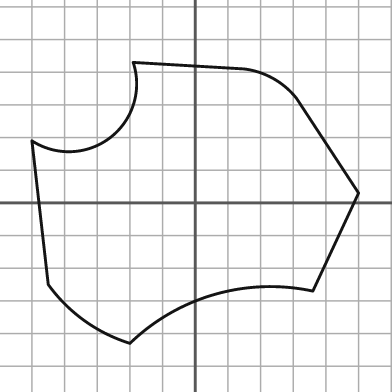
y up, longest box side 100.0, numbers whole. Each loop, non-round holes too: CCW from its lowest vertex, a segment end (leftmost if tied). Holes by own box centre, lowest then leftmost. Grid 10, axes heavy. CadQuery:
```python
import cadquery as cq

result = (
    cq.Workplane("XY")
    .moveTo(-20.0, -43.0)
    .threePointArc((6.0, -28.0), (36.0, -27.0))
    .lineTo(50.0, 3.0)
    .lineTo(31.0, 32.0)
    .threePointArc((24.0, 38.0), (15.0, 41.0))
    .lineTo(-19.0, 43.0)
    .threePointArc((-26.0, 20.0), (-50.0, 19.0))
    .lineTo(-45.0, -25.0)
    .threePointArc((-34.0, -36.0), (-20.0, -43.0))
    .close()
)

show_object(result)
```